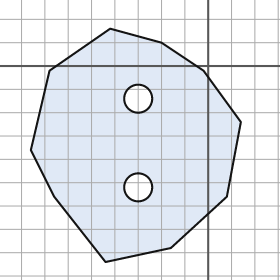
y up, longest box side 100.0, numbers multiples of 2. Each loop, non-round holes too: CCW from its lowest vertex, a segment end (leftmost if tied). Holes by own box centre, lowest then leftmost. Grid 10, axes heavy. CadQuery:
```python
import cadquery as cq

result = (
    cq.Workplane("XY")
    .moveTo(-44.0, -84.0)
    .lineTo(-16.0, -78.0)
    .lineTo(8.0, -56.0)
    .lineTo(14.0, -24.0)
    .lineTo(-2.0, -2.0)
    .lineTo(-20.0, 10.0)
    .lineTo(-42.0, 16.0)
    .lineTo(-68.0, -2.0)
    .lineTo(-76.0, -36.0)
    .lineTo(-66.0, -56.0)
    .close()
    .moveTo(-30.0, -52.0)
    .circle(6.0)
    .moveTo(-30.0, -14.0)
    .circle(6.0)
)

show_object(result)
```